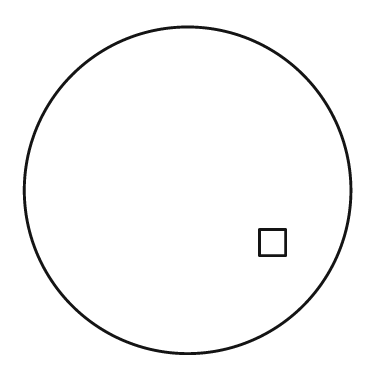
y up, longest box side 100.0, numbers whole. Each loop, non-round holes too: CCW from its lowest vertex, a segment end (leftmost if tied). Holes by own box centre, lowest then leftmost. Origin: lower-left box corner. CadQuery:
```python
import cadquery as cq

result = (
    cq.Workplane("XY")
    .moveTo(50.0, 50.0)
    .circle(50.0)
    .moveTo(72.0, 30.0)
    .lineTo(80.0, 30.0)
    .lineTo(80.0, 38.0)
    .lineTo(72.0, 38.0)
    .close()
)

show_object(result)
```